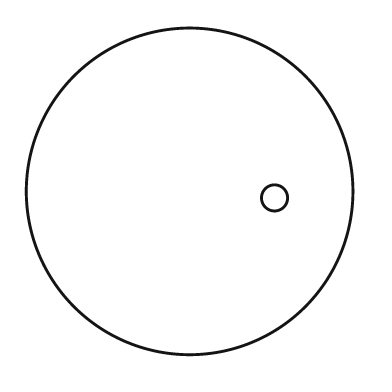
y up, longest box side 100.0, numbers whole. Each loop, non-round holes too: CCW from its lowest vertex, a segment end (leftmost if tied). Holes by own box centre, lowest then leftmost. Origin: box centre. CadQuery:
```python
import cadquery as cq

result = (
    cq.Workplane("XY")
    .moveTo(0.0, 0.0)
    .circle(50.0)
    .moveTo(26.0, -2.0)
    .circle(4.0)
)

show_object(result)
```